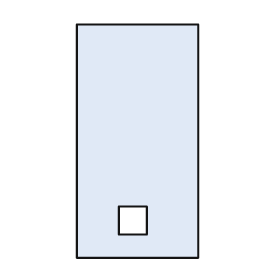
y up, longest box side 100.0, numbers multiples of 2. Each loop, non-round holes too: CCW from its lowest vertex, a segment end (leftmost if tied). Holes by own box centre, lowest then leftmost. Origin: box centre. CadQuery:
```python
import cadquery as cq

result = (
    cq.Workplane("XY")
    .moveTo(-26.0, -50.0)
    .lineTo(26.0, -50.0)
    .lineTo(26.0, 50.0)
    .lineTo(-26.0, 50.0)
    .close()
    .moveTo(-8.0, -40.0)
    .lineTo(4.0, -40.0)
    .lineTo(4.0, -28.0)
    .lineTo(-8.0, -28.0)
    .close()
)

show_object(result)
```